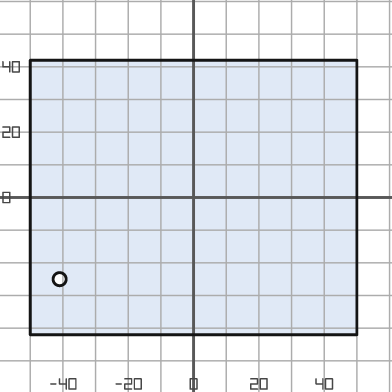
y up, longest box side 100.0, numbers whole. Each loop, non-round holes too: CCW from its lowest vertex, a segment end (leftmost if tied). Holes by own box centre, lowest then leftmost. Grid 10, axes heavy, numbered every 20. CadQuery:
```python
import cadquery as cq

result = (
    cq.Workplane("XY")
    .moveTo(-50.0, -42.0)
    .lineTo(50.0, -42.0)
    .lineTo(50.0, 42.0)
    .lineTo(-50.0, 42.0)
    .close()
    .moveTo(-41.0, -25.0)
    .circle(2.0)
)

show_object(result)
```